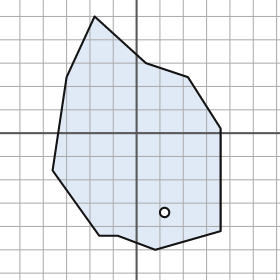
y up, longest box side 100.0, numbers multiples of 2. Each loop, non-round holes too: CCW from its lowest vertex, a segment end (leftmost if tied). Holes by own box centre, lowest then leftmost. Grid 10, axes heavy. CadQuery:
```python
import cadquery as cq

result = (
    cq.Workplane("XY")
    .moveTo(8.0, -50.0)
    .lineTo(36.0, -42.0)
    .lineTo(36.0, 2.0)
    .lineTo(22.0, 24.0)
    .lineTo(4.0, 30.0)
    .lineTo(-18.0, 50.0)
    .lineTo(-30.0, 24.0)
    .lineTo(-36.0, -16.0)
    .lineTo(-16.0, -44.0)
    .lineTo(-8.0, -44.0)
    .close()
    .moveTo(12.0, -34.0)
    .circle(2.0)
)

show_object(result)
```